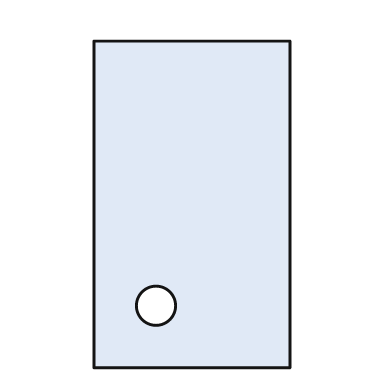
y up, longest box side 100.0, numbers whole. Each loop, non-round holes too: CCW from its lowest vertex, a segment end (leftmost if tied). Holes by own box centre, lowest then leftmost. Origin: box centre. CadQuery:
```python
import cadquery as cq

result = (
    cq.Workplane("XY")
    .moveTo(-30.0, -50.0)
    .lineTo(30.0, -50.0)
    .lineTo(30.0, 50.0)
    .lineTo(-30.0, 50.0)
    .close()
    .moveTo(-11.0, -31.0)
    .circle(6.0)
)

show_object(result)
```